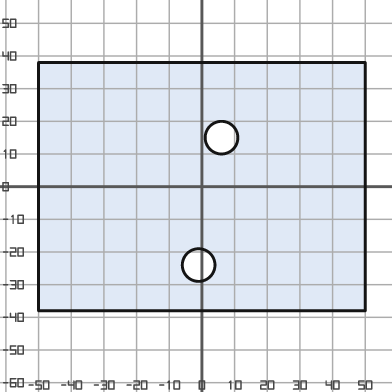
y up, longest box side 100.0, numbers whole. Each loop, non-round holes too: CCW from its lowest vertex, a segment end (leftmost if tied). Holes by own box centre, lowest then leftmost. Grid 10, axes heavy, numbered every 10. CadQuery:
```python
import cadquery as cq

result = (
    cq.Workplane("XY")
    .moveTo(-50.0, -38.0)
    .lineTo(50.0, -38.0)
    .lineTo(50.0, 38.0)
    .lineTo(-50.0, 38.0)
    .close()
    .moveTo(-1.0, -24.0)
    .circle(5.0)
    .moveTo(6.0, 15.0)
    .circle(5.0)
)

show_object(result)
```